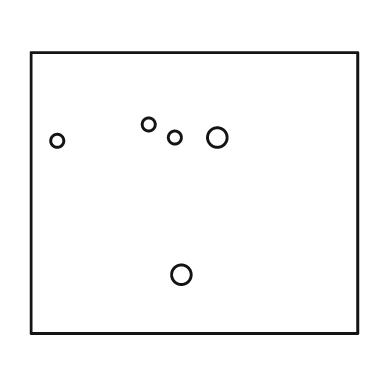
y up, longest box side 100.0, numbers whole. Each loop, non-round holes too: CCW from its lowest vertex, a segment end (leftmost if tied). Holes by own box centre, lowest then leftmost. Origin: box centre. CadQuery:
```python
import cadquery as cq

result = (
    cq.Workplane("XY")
    .moveTo(-50.0, -43.0)
    .lineTo(50.0, -43.0)
    .lineTo(50.0, 43.0)
    .lineTo(-50.0, 43.0)
    .close()
    .moveTo(-4.0, -25.0)
    .circle(3.0)
    .moveTo(-42.0, 16.0)
    .circle(2.0)
    .moveTo(-6.0, 17.0)
    .circle(2.0)
    .moveTo(7.0, 17.0)
    .circle(3.0)
    .moveTo(-14.0, 21.0)
    .circle(2.0)
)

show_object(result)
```